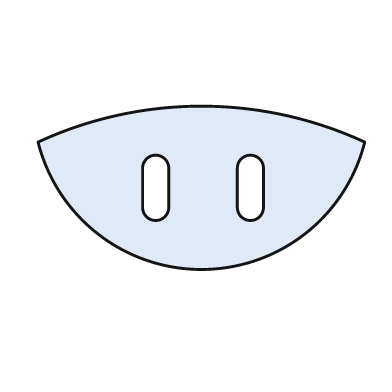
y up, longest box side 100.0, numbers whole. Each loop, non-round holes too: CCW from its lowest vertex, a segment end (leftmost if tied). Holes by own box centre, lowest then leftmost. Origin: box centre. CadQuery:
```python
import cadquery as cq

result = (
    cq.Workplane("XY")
    .moveTo(-50.0, 14.0)
    .threePointArc((0.0, -25.0), (50.0, 14.0))
    .threePointArc((0.0, 25.0), (-50.0, 14.0))
    .close()
    .moveTo(-18.0, -6.0)
    .threePointArc((-14.0, -10.0), (-10.0, -6.0))
    .lineTo(-10.0, 6.0)
    .threePointArc((-14.0, 10.0), (-18.0, 6.0))
    .close()
    .moveTo(11.0, -6.0)
    .threePointArc((15.0, -10.0), (19.0, -6.0))
    .lineTo(19.0, 6.0)
    .threePointArc((15.0, 10.0), (11.0, 6.0))
    .close()
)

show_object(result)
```